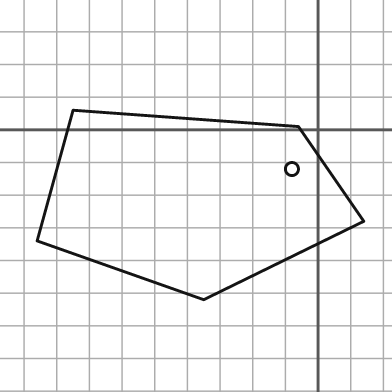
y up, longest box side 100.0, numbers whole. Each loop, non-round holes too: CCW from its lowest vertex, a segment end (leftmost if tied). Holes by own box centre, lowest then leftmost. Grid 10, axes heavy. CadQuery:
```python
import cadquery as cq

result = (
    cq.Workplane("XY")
    .moveTo(-35.0, -52.0)
    .lineTo(14.0, -28.0)
    .lineTo(-6.0, 1.0)
    .lineTo(-75.0, 6.0)
    .lineTo(-86.0, -34.0)
    .close()
    .moveTo(-8.0, -12.0)
    .circle(2.0)
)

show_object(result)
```